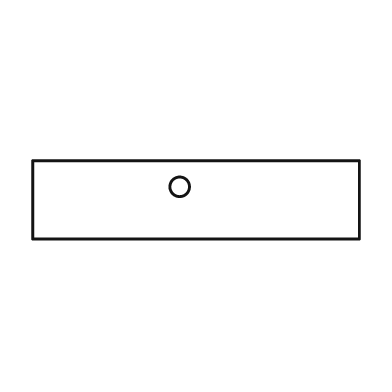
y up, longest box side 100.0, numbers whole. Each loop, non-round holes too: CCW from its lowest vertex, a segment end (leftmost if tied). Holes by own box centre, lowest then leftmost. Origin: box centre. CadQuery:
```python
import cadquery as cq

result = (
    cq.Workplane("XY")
    .moveTo(-50.0, -12.0)
    .lineTo(50.0, -12.0)
    .lineTo(50.0, 12.0)
    .lineTo(-50.0, 12.0)
    .close()
    .moveTo(-5.0, 4.0)
    .circle(3.0)
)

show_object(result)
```